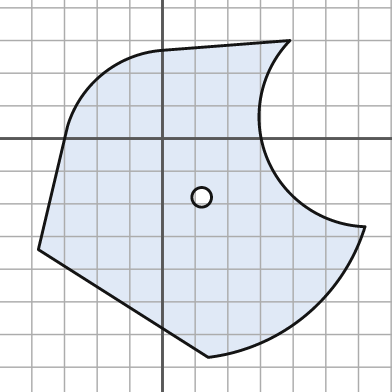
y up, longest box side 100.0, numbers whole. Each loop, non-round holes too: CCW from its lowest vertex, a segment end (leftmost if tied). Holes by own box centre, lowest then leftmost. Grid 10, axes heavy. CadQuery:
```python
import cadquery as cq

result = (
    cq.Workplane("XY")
    .moveTo(14.0, -67.0)
    .threePointArc((44.0, -54.0), (62.0, -27.0))
    .threePointArc((32.0, -6.0), (39.0, 30.0))
    .lineTo(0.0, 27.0)
    .threePointArc((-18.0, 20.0), (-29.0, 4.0))
    .lineTo(-38.0, -34.0)
    .close()
    .moveTo(12.0, -18.0)
    .circle(3.0)
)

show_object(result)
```